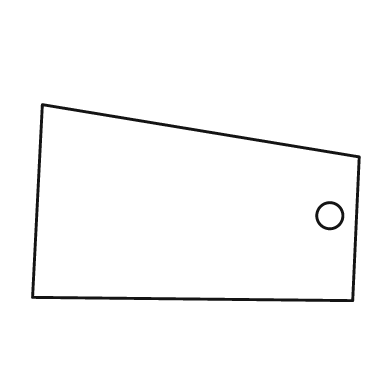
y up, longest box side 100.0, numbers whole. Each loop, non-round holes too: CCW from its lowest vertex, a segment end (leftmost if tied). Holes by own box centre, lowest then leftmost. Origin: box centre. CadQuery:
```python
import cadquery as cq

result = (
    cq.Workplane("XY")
    .moveTo(48.0, -30.0)
    .lineTo(50.0, 14.0)
    .lineTo(-47.0, 30.0)
    .lineTo(-50.0, -29.0)
    .close()
    .moveTo(41.0, -4.0)
    .circle(4.0)
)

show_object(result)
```